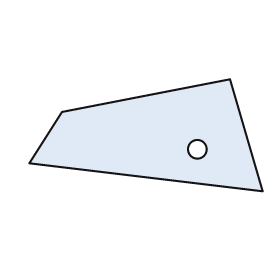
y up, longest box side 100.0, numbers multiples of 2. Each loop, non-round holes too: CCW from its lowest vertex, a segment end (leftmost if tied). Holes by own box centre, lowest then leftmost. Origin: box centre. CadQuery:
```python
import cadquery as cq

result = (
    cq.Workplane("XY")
    .moveTo(50.0, -24.0)
    .lineTo(36.0, 24.0)
    .lineTo(-36.0, 10.0)
    .lineTo(-50.0, -12.0)
    .close()
    .moveTo(22.0, -6.0)
    .circle(4.0)
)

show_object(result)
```